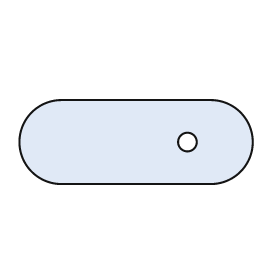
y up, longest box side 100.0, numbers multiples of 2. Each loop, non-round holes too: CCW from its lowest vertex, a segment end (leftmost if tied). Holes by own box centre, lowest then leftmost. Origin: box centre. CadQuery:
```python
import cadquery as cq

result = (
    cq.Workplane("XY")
    .moveTo(-32.0, -18.0)
    .lineTo(32.0, -18.0)
    .threePointArc((50.0, 0.0), (32.0, 18.0))
    .lineTo(-32.0, 18.0)
    .threePointArc((-50.0, 0.0), (-32.0, -18.0))
    .close()
    .moveTo(22.0, 0.0)
    .circle(4.0)
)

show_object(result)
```